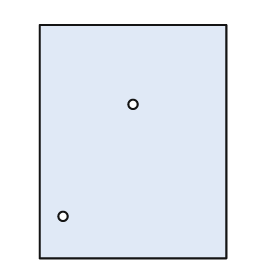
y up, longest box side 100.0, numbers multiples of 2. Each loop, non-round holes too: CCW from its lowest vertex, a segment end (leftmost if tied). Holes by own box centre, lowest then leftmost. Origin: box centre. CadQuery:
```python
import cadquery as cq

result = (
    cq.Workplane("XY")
    .moveTo(-40.0, -50.0)
    .lineTo(40.0, -50.0)
    .lineTo(40.0, 50.0)
    .lineTo(-40.0, 50.0)
    .close()
    .moveTo(-30.0, -32.0)
    .circle(2.0)
    .moveTo(0.0, 16.0)
    .circle(2.0)
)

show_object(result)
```